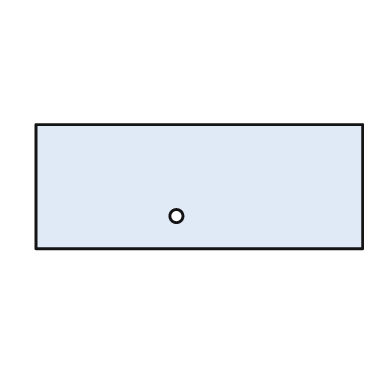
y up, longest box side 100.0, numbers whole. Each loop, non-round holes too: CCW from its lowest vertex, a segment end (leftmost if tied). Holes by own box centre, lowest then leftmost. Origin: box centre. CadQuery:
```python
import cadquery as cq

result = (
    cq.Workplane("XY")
    .moveTo(-50.0, -19.0)
    .lineTo(50.0, -19.0)
    .lineTo(50.0, 19.0)
    .lineTo(-50.0, 19.0)
    .close()
    .moveTo(-7.0, -9.0)
    .circle(2.0)
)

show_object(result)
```